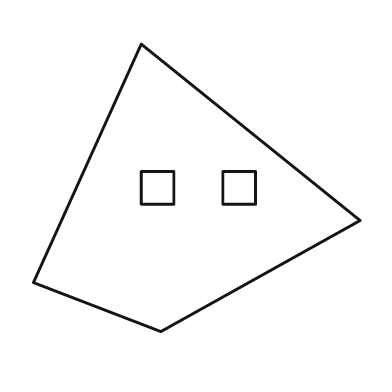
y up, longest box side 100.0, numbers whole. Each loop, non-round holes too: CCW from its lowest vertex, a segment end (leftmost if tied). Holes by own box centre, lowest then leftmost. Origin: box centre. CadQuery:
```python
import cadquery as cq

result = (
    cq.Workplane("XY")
    .moveTo(-11.0, -44.0)
    .lineTo(50.0, -10.0)
    .lineTo(-17.0, 44.0)
    .lineTo(-50.0, -29.0)
    .close()
    .moveTo(-17.0, -5.0)
    .lineTo(-7.0, -5.0)
    .lineTo(-7.0, 5.0)
    .lineTo(-17.0, 5.0)
    .close()
    .moveTo(8.0, -5.0)
    .lineTo(18.0, -5.0)
    .lineTo(18.0, 5.0)
    .lineTo(8.0, 5.0)
    .close()
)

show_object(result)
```